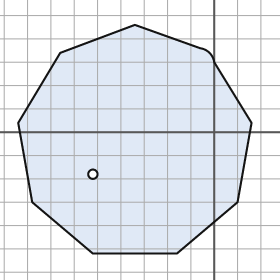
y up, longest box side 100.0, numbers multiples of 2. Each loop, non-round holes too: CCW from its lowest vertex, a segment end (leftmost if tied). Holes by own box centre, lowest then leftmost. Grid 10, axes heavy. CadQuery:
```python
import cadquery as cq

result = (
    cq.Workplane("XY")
    .moveTo(-52.0, -52.0)
    .lineTo(-16.0, -52.0)
    .lineTo(10.0, -30.0)
    .lineTo(16.0, 4.0)
    .lineTo(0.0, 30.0)
    .threePointArc((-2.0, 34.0), (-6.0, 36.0))
    .lineTo(-34.0, 46.0)
    .lineTo(-66.0, 34.0)
    .lineTo(-84.0, 4.0)
    .lineTo(-78.0, -30.0)
    .close()
    .moveTo(-52.0, -18.0)
    .circle(2.0)
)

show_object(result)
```